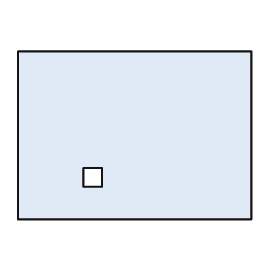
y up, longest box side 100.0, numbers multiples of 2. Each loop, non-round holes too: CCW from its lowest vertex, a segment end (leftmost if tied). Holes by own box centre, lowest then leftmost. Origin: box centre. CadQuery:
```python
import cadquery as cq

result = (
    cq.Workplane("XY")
    .moveTo(-50.0, -36.0)
    .lineTo(50.0, -36.0)
    .lineTo(50.0, 36.0)
    .lineTo(-50.0, 36.0)
    .close()
    .moveTo(-22.0, -22.0)
    .lineTo(-14.0, -22.0)
    .lineTo(-14.0, -14.0)
    .lineTo(-22.0, -14.0)
    .close()
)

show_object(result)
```